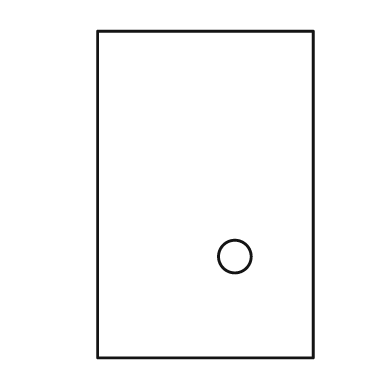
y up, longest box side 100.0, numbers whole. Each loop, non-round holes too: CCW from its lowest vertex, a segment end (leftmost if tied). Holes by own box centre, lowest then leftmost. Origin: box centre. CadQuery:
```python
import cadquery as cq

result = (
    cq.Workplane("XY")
    .moveTo(-33.0, -50.0)
    .lineTo(33.0, -50.0)
    .lineTo(33.0, 50.0)
    .lineTo(-33.0, 50.0)
    .close()
    .moveTo(9.0, -19.0)
    .circle(5.0)
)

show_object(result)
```